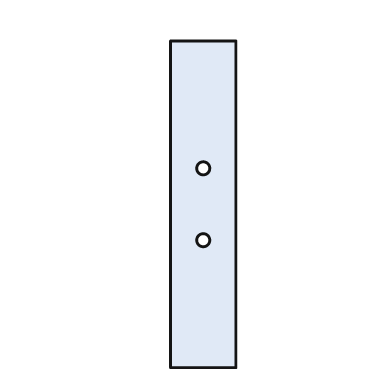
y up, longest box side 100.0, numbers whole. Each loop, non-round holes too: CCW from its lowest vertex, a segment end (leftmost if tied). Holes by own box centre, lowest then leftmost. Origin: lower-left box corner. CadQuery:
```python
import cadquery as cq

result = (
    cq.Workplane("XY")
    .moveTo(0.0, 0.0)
    .lineTo(20.0, 0.0)
    .lineTo(20.0, 100.0)
    .lineTo(0.0, 100.0)
    .close()
    .moveTo(10.0, 39.0)
    .circle(2.0)
    .moveTo(10.0, 61.0)
    .circle(2.0)
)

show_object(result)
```